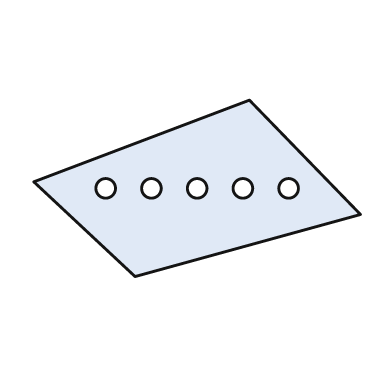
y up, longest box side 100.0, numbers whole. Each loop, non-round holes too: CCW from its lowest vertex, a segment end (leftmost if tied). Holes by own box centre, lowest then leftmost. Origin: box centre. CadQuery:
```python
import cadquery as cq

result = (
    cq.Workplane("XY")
    .moveTo(-19.0, -27.0)
    .lineTo(50.0, -8.0)
    .lineTo(16.0, 27.0)
    .lineTo(-50.0, 2.0)
    .close()
    .moveTo(-28.0, 0.0)
    .circle(3.0)
    .moveTo(-14.0, 0.0)
    .circle(3.0)
    .moveTo(0.0, 0.0)
    .circle(3.0)
    .moveTo(14.0, 0.0)
    .circle(3.0)
    .moveTo(28.0, 0.0)
    .circle(3.0)
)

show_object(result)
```